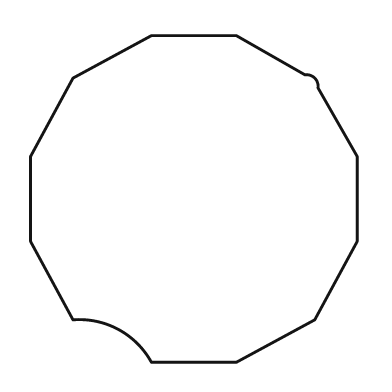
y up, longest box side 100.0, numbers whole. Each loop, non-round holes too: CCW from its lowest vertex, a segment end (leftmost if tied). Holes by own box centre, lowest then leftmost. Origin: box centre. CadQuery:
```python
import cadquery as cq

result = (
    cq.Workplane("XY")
    .moveTo(-13.0, -50.0)
    .lineTo(13.0, -50.0)
    .lineTo(37.0, -37.0)
    .lineTo(50.0, -13.0)
    .lineTo(50.0, 13.0)
    .lineTo(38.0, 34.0)
    .threePointArc((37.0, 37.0), (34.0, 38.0))
    .lineTo(13.0, 50.0)
    .lineTo(-13.0, 50.0)
    .lineTo(-37.0, 37.0)
    .lineTo(-50.0, 13.0)
    .lineTo(-50.0, -13.0)
    .lineTo(-37.0, -37.0)
    .threePointArc((-23.0, -40.0), (-13.0, -50.0))
    .close()
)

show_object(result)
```